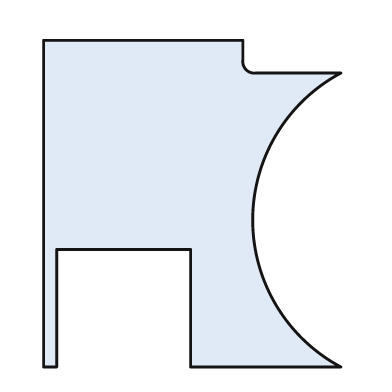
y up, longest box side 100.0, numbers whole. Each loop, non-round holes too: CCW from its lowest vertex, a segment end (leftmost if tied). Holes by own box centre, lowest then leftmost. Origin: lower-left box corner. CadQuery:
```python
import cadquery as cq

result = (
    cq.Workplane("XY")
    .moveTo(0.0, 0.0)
    .lineTo(4.0, 0.0)
    .lineTo(4.0, 36.0)
    .lineTo(45.0, 36.0)
    .lineTo(45.0, 0.0)
    .lineTo(91.0, 0.0)
    .threePointArc((64.0, 45.0), (91.0, 90.0))
    .lineTo(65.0, 90.0)
    .threePointArc((62.0, 91.0), (61.0, 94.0))
    .lineTo(61.0, 100.0)
    .lineTo(0.0, 100.0)
    .close()
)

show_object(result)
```